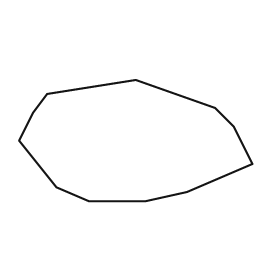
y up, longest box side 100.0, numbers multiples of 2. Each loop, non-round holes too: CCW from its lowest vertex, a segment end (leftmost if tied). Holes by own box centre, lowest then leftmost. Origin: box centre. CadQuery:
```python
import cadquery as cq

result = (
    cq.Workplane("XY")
    .moveTo(-20.0, -26.0)
    .lineTo(4.0, -26.0)
    .lineTo(22.0, -22.0)
    .lineTo(50.0, -10.0)
    .lineTo(42.0, 6.0)
    .lineTo(34.0, 14.0)
    .lineTo(0.0, 26.0)
    .lineTo(-38.0, 20.0)
    .lineTo(-44.0, 12.0)
    .lineTo(-50.0, 0.0)
    .lineTo(-34.0, -20.0)
    .close()
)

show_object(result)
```